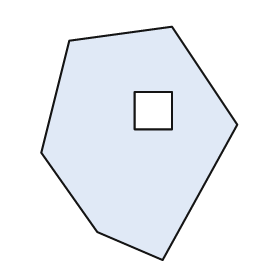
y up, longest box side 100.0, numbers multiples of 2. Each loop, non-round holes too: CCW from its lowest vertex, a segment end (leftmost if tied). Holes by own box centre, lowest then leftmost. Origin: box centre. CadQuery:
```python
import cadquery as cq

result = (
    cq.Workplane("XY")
    .moveTo(10.0, -50.0)
    .lineTo(42.0, 8.0)
    .lineTo(14.0, 50.0)
    .lineTo(-30.0, 44.0)
    .lineTo(-42.0, -4.0)
    .lineTo(-18.0, -38.0)
    .close()
    .moveTo(-2.0, 6.0)
    .lineTo(14.0, 6.0)
    .lineTo(14.0, 22.0)
    .lineTo(-2.0, 22.0)
    .close()
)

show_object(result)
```